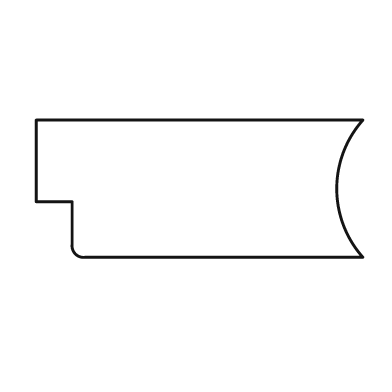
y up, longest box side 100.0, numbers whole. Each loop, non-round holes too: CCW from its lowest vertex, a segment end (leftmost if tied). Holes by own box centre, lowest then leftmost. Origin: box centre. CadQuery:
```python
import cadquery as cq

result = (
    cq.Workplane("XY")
    .moveTo(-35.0, -21.0)
    .lineTo(50.0, -21.0)
    .threePointArc((42.0, 0.0), (50.0, 21.0))
    .lineTo(-50.0, 21.0)
    .lineTo(-50.0, -4.0)
    .lineTo(-39.0, -4.0)
    .lineTo(-39.0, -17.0)
    .threePointArc((-38.0, -20.0), (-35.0, -21.0))
    .close()
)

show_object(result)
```